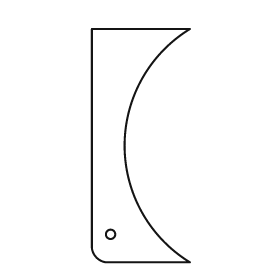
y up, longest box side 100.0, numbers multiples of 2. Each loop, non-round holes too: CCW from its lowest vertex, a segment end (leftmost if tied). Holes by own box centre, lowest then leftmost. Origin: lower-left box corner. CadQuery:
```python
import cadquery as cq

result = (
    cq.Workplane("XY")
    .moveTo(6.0, 0.0)
    .lineTo(42.0, 0.0)
    .threePointArc((14.0, 50.0), (42.0, 100.0))
    .lineTo(0.0, 100.0)
    .lineTo(0.0, 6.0)
    .threePointArc((2.0, 2.0), (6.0, 0.0))
    .close()
    .moveTo(8.0, 12.0)
    .circle(2.0)
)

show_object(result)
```